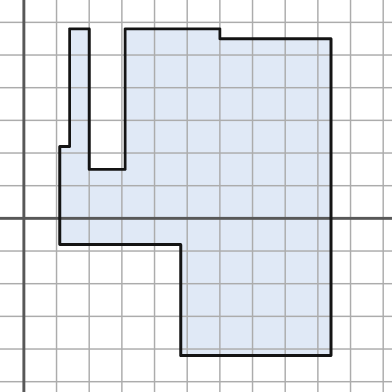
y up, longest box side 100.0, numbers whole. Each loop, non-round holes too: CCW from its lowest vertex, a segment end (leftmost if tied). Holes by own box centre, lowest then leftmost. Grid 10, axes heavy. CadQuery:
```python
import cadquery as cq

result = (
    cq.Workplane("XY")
    .moveTo(48.0, -42.0)
    .lineTo(94.0, -42.0)
    .lineTo(94.0, 55.0)
    .lineTo(60.0, 55.0)
    .lineTo(60.0, 58.0)
    .lineTo(31.0, 58.0)
    .lineTo(31.0, 15.0)
    .lineTo(20.0, 15.0)
    .lineTo(20.0, 58.0)
    .lineTo(14.0, 58.0)
    .lineTo(14.0, 22.0)
    .lineTo(11.0, 22.0)
    .lineTo(11.0, -8.0)
    .lineTo(48.0, -8.0)
    .close()
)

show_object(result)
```